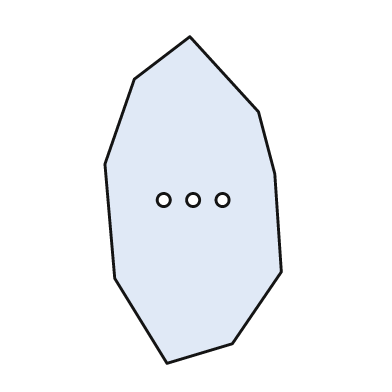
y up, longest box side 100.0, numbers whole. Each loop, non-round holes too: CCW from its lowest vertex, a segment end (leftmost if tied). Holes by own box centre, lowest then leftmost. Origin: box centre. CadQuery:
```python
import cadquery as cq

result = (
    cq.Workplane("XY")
    .moveTo(-8.0, -50.0)
    .lineTo(12.0, -44.0)
    .lineTo(27.0, -22.0)
    .lineTo(25.0, 8.0)
    .lineTo(20.0, 27.0)
    .lineTo(-1.0, 50.0)
    .lineTo(-18.0, 37.0)
    .lineTo(-27.0, 11.0)
    .lineTo(-24.0, -24.0)
    .close()
    .moveTo(-9.0, 0.0)
    .circle(2.0)
    .moveTo(0.0, 0.0)
    .circle(2.0)
    .moveTo(9.0, 0.0)
    .circle(2.0)
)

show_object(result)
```